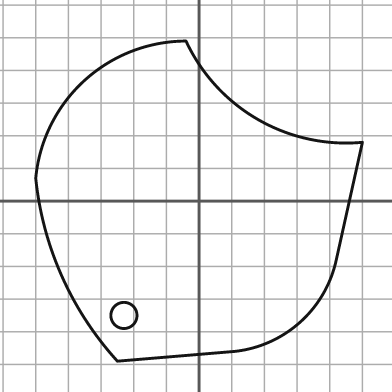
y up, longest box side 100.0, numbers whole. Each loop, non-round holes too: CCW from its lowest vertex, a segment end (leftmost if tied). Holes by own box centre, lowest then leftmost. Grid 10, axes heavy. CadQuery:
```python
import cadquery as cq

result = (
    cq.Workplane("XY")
    .moveTo(-25.0, -49.0)
    .lineTo(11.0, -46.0)
    .threePointArc((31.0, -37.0), (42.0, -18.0))
    .lineTo(50.0, 18.0)
    .threePointArc((18.0, 25.0), (-4.0, 49.0))
    .threePointArc((-35.0, 37.0), (-50.0, 7.0))
    .threePointArc((-42.0, -23.0), (-25.0, -49.0))
    .close()
    .moveTo(-23.0, -35.0)
    .circle(4.0)
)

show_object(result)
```